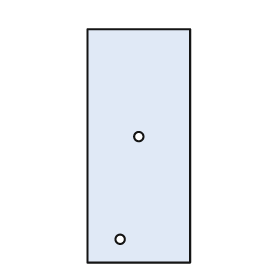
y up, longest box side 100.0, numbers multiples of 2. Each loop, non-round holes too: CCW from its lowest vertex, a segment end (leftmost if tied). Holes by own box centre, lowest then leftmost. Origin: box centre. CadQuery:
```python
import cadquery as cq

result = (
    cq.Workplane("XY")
    .moveTo(-22.0, -50.0)
    .lineTo(22.0, -50.0)
    .lineTo(22.0, 50.0)
    .lineTo(-22.0, 50.0)
    .close()
    .moveTo(-8.0, -40.0)
    .circle(2.0)
    .moveTo(0.0, 4.0)
    .circle(2.0)
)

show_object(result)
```